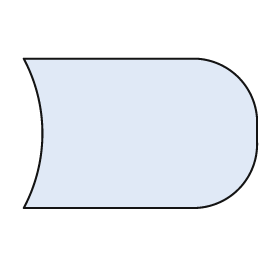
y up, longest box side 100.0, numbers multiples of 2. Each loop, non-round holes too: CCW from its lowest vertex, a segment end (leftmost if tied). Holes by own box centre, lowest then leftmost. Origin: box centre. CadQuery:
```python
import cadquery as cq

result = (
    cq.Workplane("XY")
    .moveTo(-50.0, -32.0)
    .lineTo(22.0, -32.0)
    .threePointArc((42.0, -24.0), (50.0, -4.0))
    .lineTo(50.0, 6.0)
    .threePointArc((42.0, 24.0), (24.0, 32.0))
    .lineTo(-50.0, 32.0)
    .threePointArc((-42.0, 0.0), (-50.0, -32.0))
    .close()
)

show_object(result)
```